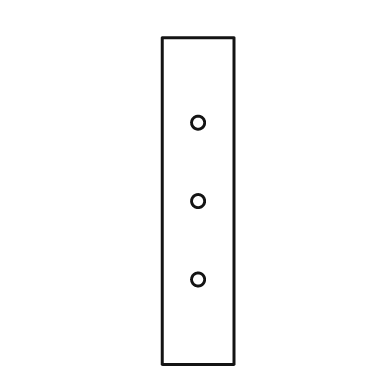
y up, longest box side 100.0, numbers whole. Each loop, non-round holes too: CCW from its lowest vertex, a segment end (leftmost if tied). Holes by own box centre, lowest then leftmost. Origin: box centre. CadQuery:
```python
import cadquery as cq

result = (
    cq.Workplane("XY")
    .moveTo(-11.0, -50.0)
    .lineTo(11.0, -50.0)
    .lineTo(11.0, 50.0)
    .lineTo(-11.0, 50.0)
    .close()
    .moveTo(0.0, -24.0)
    .circle(2.0)
    .moveTo(0.0, 0.0)
    .circle(2.0)
    .moveTo(0.0, 24.0)
    .circle(2.0)
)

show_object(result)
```